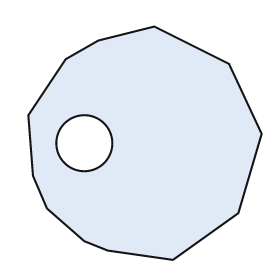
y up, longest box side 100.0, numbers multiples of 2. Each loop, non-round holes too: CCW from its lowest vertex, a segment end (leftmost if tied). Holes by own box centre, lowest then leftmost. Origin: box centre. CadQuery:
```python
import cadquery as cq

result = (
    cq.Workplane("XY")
    .moveTo(12.0, -50.0)
    .lineTo(40.0, -30.0)
    .lineTo(50.0, 4.0)
    .lineTo(36.0, 34.0)
    .lineTo(4.0, 50.0)
    .lineTo(-20.0, 44.0)
    .lineTo(-34.0, 36.0)
    .lineTo(-50.0, 12.0)
    .lineTo(-48.0, -14.0)
    .lineTo(-42.0, -28.0)
    .lineTo(-26.0, -42.0)
    .lineTo(-16.0, -46.0)
    .close()
    .moveTo(-26.0, 0.0)
    .circle(12.0)
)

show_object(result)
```